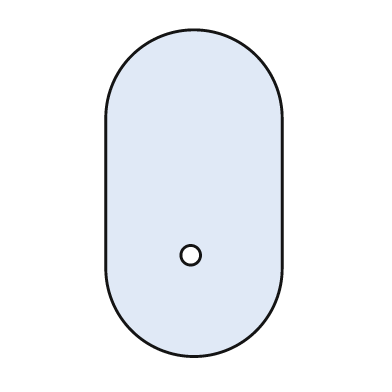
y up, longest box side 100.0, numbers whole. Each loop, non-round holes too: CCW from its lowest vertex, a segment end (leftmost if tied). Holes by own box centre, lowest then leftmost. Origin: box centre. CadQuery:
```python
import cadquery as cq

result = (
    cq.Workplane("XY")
    .moveTo(-27.0, -23.0)
    .threePointArc((0.0, -50.0), (27.0, -23.0))
    .lineTo(27.0, 23.0)
    .threePointArc((0.0, 50.0), (-27.0, 23.0))
    .close()
    .moveTo(-1.0, -19.0)
    .circle(3.0)
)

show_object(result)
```